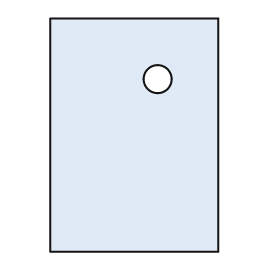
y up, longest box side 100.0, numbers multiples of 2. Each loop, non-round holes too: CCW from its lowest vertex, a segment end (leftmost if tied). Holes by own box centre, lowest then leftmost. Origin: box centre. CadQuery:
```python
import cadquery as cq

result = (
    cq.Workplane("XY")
    .moveTo(-36.0, -50.0)
    .lineTo(36.0, -50.0)
    .lineTo(36.0, 50.0)
    .lineTo(-36.0, 50.0)
    .close()
    .moveTo(10.0, 24.0)
    .circle(6.0)
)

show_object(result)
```